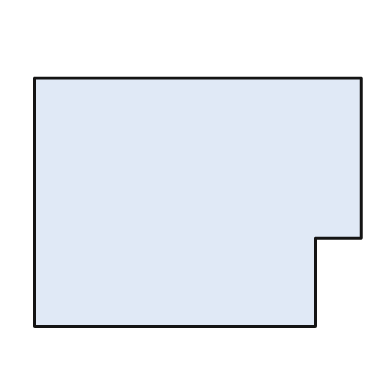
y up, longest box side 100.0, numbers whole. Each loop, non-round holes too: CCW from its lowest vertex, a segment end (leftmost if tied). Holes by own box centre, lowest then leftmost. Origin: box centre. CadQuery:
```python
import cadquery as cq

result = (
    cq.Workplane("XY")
    .moveTo(-50.0, -38.0)
    .lineTo(36.0, -38.0)
    .lineTo(36.0, -11.0)
    .lineTo(50.0, -11.0)
    .lineTo(50.0, 38.0)
    .lineTo(-50.0, 38.0)
    .close()
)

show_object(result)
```